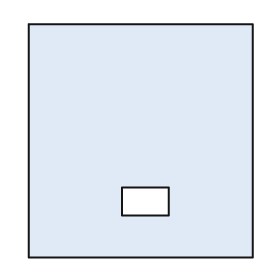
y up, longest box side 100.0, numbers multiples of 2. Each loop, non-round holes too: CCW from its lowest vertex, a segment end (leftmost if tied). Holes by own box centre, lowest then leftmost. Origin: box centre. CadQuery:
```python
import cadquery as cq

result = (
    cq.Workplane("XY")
    .moveTo(-48.0, -50.0)
    .lineTo(48.0, -50.0)
    .lineTo(48.0, 50.0)
    .lineTo(-48.0, 50.0)
    .close()
    .moveTo(-8.0, -32.0)
    .lineTo(12.0, -32.0)
    .lineTo(12.0, -20.0)
    .lineTo(-8.0, -20.0)
    .close()
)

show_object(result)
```